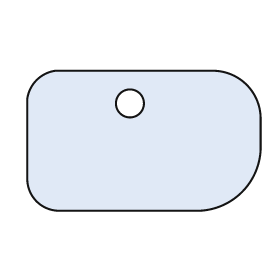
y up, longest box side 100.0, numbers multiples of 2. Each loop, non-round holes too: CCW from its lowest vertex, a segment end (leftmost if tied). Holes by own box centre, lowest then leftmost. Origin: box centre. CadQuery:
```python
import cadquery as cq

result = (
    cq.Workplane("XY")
    .moveTo(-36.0, -30.0)
    .lineTo(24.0, -30.0)
    .threePointArc((42.0, -22.0), (50.0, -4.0))
    .lineTo(50.0, 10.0)
    .threePointArc((44.0, 24.0), (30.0, 30.0))
    .lineTo(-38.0, 30.0)
    .threePointArc((-46.0, 26.0), (-50.0, 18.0))
    .lineTo(-50.0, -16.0)
    .threePointArc((-46.0, -26.0), (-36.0, -30.0))
    .close()
    .moveTo(-6.0, 16.0)
    .circle(6.0)
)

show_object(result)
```